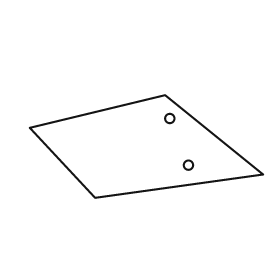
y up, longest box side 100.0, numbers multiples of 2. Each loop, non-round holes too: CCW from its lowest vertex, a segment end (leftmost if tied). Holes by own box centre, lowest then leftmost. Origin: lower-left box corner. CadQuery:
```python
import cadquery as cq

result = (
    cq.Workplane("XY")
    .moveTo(28.0, 0.0)
    .lineTo(100.0, 10.0)
    .lineTo(58.0, 44.0)
    .lineTo(0.0, 30.0)
    .close()
    .moveTo(68.0, 14.0)
    .circle(2.0)
    .moveTo(60.0, 34.0)
    .circle(2.0)
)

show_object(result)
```